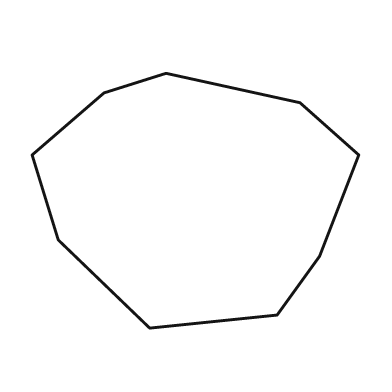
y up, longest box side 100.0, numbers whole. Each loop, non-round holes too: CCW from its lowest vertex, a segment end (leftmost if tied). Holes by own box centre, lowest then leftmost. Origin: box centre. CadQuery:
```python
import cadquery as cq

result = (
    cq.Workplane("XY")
    .moveTo(-14.0, -39.0)
    .lineTo(25.0, -35.0)
    .lineTo(38.0, -17.0)
    .lineTo(50.0, 14.0)
    .lineTo(32.0, 30.0)
    .lineTo(-9.0, 39.0)
    .lineTo(-28.0, 33.0)
    .lineTo(-50.0, 14.0)
    .lineTo(-42.0, -12.0)
    .close()
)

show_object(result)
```